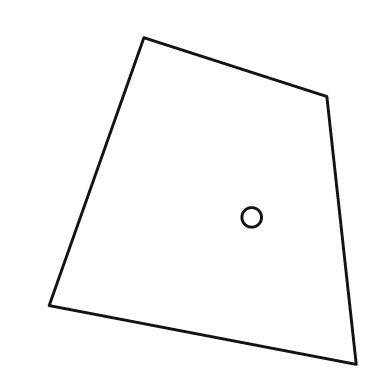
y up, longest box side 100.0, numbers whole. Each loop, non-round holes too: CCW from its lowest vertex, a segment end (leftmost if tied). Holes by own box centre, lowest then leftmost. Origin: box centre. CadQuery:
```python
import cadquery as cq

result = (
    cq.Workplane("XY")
    .moveTo(47.0, -50.0)
    .lineTo(38.0, 32.0)
    .lineTo(-18.0, 50.0)
    .lineTo(-47.0, -32.0)
    .close()
    .moveTo(15.0, -5.0)
    .circle(3.0)
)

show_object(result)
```